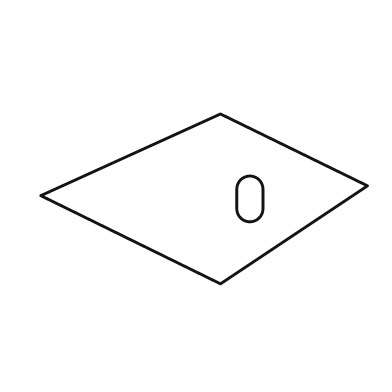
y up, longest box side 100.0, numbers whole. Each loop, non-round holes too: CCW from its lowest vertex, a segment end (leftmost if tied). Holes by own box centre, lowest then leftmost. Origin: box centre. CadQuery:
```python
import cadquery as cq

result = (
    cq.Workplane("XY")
    .moveTo(5.0, -26.0)
    .lineTo(50.0, 4.0)
    .lineTo(5.0, 26.0)
    .lineTo(-50.0, 1.0)
    .close()
    .moveTo(10.0, -3.0)
    .threePointArc((14.0, -7.0), (18.0, -3.0))
    .lineTo(18.0, 3.0)
    .threePointArc((14.0, 7.0), (10.0, 3.0))
    .close()
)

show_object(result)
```